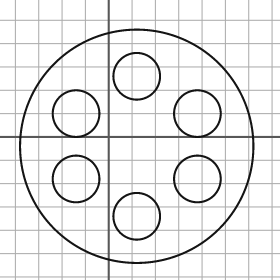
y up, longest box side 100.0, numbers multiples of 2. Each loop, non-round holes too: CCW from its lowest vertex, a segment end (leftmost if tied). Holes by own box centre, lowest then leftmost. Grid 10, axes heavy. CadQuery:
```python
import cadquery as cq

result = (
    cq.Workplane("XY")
    .moveTo(12.0, -4.0)
    .circle(50.0)
    .moveTo(12.0, -34.0)
    .circle(10.0)
    .moveTo(-14.0, -18.0)
    .circle(10.0)
    .moveTo(38.0, -18.0)
    .circle(10.0)
    .moveTo(-14.0, 10.0)
    .circle(10.0)
    .moveTo(38.0, 10.0)
    .circle(10.0)
    .moveTo(12.0, 26.0)
    .circle(10.0)
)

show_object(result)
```